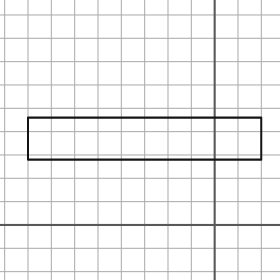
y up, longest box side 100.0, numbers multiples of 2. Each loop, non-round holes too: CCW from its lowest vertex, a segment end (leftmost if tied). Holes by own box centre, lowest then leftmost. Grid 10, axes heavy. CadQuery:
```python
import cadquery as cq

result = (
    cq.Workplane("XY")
    .moveTo(-80.0, 28.0)
    .lineTo(20.0, 28.0)
    .lineTo(20.0, 46.0)
    .lineTo(-80.0, 46.0)
    .close()
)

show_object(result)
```